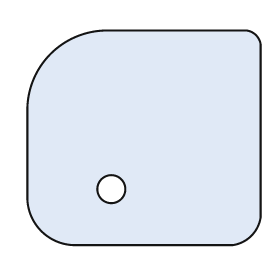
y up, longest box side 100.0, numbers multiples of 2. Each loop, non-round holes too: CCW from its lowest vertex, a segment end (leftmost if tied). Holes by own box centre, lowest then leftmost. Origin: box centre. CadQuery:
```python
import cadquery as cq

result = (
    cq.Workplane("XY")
    .moveTo(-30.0, -46.0)
    .lineTo(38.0, -46.0)
    .threePointArc((46.0, -42.0), (50.0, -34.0))
    .lineTo(50.0, 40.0)
    .threePointArc((48.0, 44.0), (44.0, 46.0))
    .lineTo(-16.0, 46.0)
    .threePointArc((-40.0, 36.0), (-50.0, 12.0))
    .lineTo(-50.0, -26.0)
    .threePointArc((-44.0, -40.0), (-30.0, -46.0))
    .close()
    .moveTo(-14.0, -22.0)
    .circle(6.0)
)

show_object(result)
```